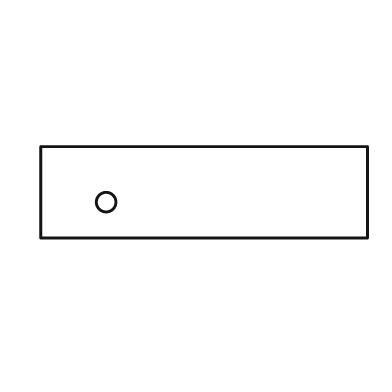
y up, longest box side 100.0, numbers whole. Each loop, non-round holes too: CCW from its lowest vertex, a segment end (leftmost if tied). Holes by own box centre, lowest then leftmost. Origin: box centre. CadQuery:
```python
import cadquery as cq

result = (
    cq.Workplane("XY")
    .moveTo(-50.0, -14.0)
    .lineTo(50.0, -14.0)
    .lineTo(50.0, 14.0)
    .lineTo(-50.0, 14.0)
    .close()
    .moveTo(-30.0, -3.0)
    .circle(3.0)
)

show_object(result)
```